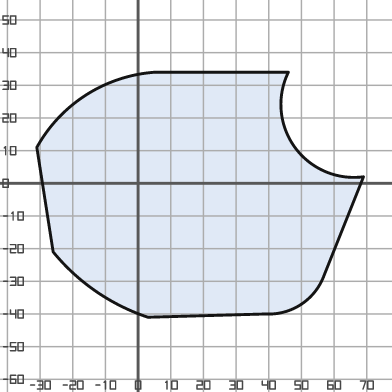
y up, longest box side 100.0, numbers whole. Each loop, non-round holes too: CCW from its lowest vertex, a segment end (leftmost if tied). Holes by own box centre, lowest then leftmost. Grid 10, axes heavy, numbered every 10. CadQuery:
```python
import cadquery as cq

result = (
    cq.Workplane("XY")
    .moveTo(3.0, -41.0)
    .lineTo(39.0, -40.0)
    .threePointArc((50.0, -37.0), (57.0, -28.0))
    .lineTo(69.0, 2.0)
    .threePointArc((48.0, 11.0), (46.0, 34.0))
    .lineTo(5.0, 34.0)
    .threePointArc((-16.0, 27.0), (-31.0, 11.0))
    .lineTo(-26.0, -21.0)
    .threePointArc((-13.0, -33.0), (3.0, -41.0))
    .close()
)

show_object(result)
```